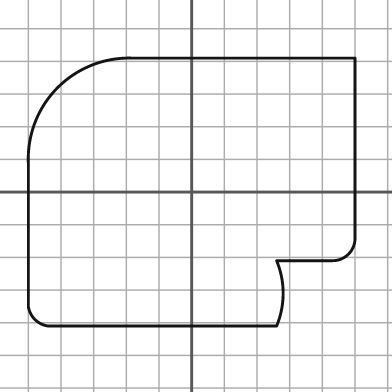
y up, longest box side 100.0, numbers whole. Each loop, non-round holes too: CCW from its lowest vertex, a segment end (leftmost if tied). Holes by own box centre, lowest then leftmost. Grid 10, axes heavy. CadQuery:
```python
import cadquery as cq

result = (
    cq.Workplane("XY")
    .moveTo(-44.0, -41.0)
    .lineTo(26.0, -41.0)
    .threePointArc((28.0, -31.0), (26.0, -21.0))
    .lineTo(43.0, -21.0)
    .threePointArc((48.0, -19.0), (50.0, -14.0))
    .lineTo(50.0, 41.0)
    .lineTo(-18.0, 41.0)
    .threePointArc((-41.0, 32.0), (-50.0, 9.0))
    .lineTo(-50.0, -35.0)
    .threePointArc((-48.0, -39.0), (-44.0, -41.0))
    .close()
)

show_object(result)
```